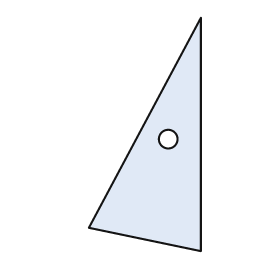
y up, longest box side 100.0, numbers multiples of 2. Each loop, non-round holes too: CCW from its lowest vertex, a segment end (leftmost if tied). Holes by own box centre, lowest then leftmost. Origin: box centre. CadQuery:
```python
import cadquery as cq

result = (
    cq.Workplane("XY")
    .moveTo(24.0, -50.0)
    .lineTo(24.0, 50.0)
    .lineTo(-24.0, -40.0)
    .close()
    .moveTo(10.0, -2.0)
    .circle(4.0)
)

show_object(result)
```